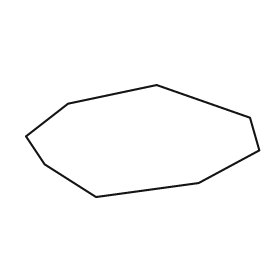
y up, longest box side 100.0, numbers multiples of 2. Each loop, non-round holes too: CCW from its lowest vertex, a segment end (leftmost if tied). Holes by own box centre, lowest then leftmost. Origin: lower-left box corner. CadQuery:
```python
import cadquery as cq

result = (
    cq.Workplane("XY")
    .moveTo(30.0, 0.0)
    .lineTo(74.0, 6.0)
    .lineTo(100.0, 20.0)
    .lineTo(96.0, 34.0)
    .lineTo(56.0, 48.0)
    .lineTo(18.0, 40.0)
    .lineTo(0.0, 26.0)
    .lineTo(8.0, 14.0)
    .close()
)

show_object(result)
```